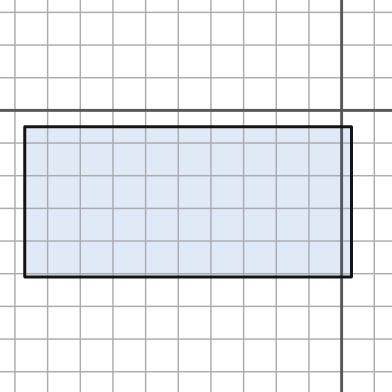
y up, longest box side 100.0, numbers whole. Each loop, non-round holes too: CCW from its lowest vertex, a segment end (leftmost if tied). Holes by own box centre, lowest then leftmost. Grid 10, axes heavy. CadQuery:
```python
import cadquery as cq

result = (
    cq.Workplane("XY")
    .moveTo(-97.0, -51.0)
    .lineTo(3.0, -51.0)
    .lineTo(3.0, -5.0)
    .lineTo(-97.0, -5.0)
    .close()
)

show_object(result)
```